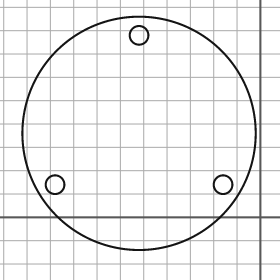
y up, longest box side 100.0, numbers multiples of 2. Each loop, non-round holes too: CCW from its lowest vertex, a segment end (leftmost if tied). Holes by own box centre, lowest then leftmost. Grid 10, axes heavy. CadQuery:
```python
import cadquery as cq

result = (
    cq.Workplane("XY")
    .moveTo(-52.0, 36.0)
    .circle(50.0)
    .moveTo(-88.0, 14.0)
    .circle(4.0)
    .moveTo(-16.0, 14.0)
    .circle(4.0)
    .moveTo(-52.0, 78.0)
    .circle(4.0)
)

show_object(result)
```